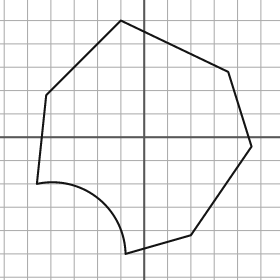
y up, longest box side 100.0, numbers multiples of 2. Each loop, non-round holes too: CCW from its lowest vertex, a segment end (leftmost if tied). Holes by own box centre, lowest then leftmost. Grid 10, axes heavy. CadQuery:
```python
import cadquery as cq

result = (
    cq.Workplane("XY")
    .moveTo(-8.0, -50.0)
    .lineTo(20.0, -42.0)
    .lineTo(46.0, -4.0)
    .lineTo(36.0, 28.0)
    .lineTo(-10.0, 50.0)
    .lineTo(-42.0, 18.0)
    .lineTo(-46.0, -20.0)
    .threePointArc((-20.0, -26.0), (-8.0, -50.0))
    .close()
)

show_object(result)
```